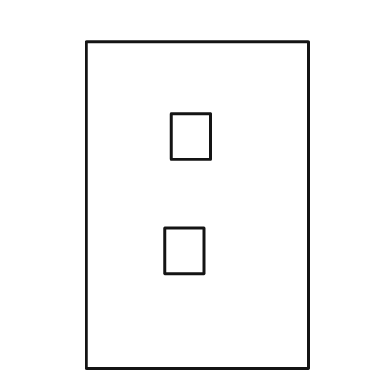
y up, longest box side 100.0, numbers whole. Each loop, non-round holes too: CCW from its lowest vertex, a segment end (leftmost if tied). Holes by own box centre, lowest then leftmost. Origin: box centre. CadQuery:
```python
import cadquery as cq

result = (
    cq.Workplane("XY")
    .moveTo(-34.0, -50.0)
    .lineTo(34.0, -50.0)
    .lineTo(34.0, 50.0)
    .lineTo(-34.0, 50.0)
    .close()
    .moveTo(-10.0, -21.0)
    .lineTo(2.0, -21.0)
    .lineTo(2.0, -7.0)
    .lineTo(-10.0, -7.0)
    .close()
    .moveTo(-8.0, 14.0)
    .lineTo(4.0, 14.0)
    .lineTo(4.0, 28.0)
    .lineTo(-8.0, 28.0)
    .close()
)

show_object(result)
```